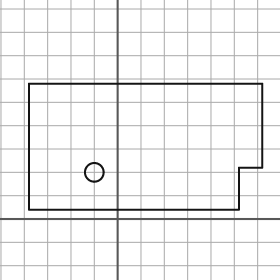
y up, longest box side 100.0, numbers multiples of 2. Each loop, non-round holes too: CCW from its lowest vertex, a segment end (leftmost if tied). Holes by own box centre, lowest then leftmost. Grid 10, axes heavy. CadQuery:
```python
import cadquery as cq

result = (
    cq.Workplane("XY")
    .moveTo(-38.0, 4.0)
    .lineTo(52.0, 4.0)
    .lineTo(52.0, 22.0)
    .lineTo(62.0, 22.0)
    .lineTo(62.0, 58.0)
    .lineTo(-38.0, 58.0)
    .close()
    .moveTo(-10.0, 20.0)
    .circle(4.0)
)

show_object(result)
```